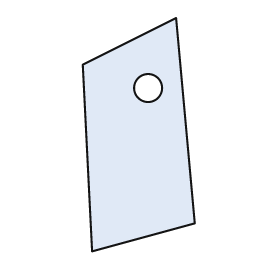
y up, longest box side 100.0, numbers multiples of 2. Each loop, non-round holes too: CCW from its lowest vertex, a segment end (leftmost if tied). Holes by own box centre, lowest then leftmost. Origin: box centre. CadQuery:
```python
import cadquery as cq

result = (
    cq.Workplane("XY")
    .moveTo(-20.0, -50.0)
    .lineTo(24.0, -38.0)
    .lineTo(16.0, 50.0)
    .lineTo(-24.0, 30.0)
    .close()
    .moveTo(4.0, 20.0)
    .circle(6.0)
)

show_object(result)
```